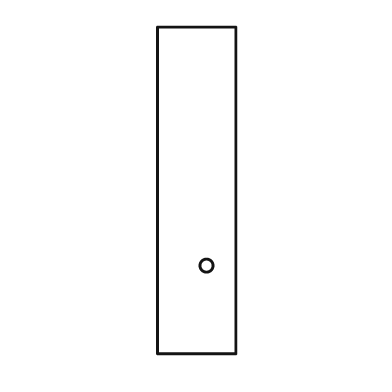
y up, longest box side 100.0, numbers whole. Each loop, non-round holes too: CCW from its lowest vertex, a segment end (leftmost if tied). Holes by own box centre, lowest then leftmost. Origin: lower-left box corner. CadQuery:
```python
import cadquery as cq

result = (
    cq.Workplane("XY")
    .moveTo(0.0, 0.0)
    .lineTo(24.0, 0.0)
    .lineTo(24.0, 100.0)
    .lineTo(0.0, 100.0)
    .close()
    .moveTo(15.0, 27.0)
    .circle(2.0)
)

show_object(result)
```